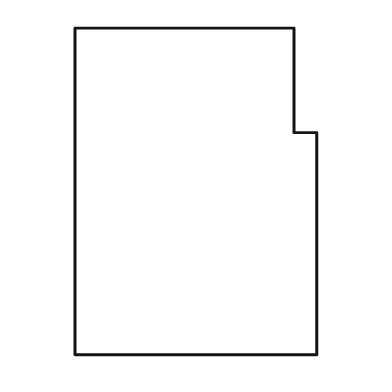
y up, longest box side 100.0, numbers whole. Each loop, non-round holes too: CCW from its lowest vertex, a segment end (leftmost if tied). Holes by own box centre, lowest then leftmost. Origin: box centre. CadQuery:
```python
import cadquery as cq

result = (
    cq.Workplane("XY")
    .moveTo(-37.0, -50.0)
    .lineTo(37.0, -50.0)
    .lineTo(37.0, 18.0)
    .lineTo(30.0, 18.0)
    .lineTo(30.0, 50.0)
    .lineTo(-37.0, 50.0)
    .close()
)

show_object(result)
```